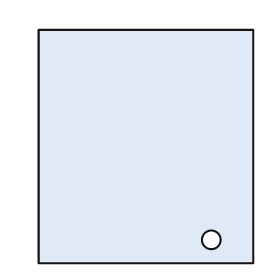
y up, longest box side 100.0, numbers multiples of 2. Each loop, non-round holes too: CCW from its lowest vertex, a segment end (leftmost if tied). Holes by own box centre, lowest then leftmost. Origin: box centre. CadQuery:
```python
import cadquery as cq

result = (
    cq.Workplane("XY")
    .moveTo(-46.0, -50.0)
    .lineTo(46.0, -50.0)
    .lineTo(46.0, 50.0)
    .lineTo(-46.0, 50.0)
    .close()
    .moveTo(28.0, -40.0)
    .circle(4.0)
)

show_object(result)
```